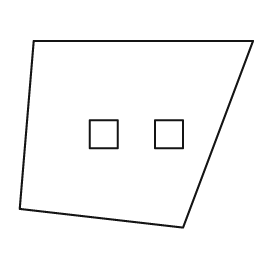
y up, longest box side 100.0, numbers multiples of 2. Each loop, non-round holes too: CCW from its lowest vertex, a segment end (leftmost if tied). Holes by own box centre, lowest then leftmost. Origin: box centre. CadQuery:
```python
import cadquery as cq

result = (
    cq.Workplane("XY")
    .moveTo(20.0, -40.0)
    .lineTo(50.0, 40.0)
    .lineTo(-44.0, 40.0)
    .lineTo(-50.0, -32.0)
    .close()
    .moveTo(-20.0, -6.0)
    .lineTo(-8.0, -6.0)
    .lineTo(-8.0, 6.0)
    .lineTo(-20.0, 6.0)
    .close()
    .moveTo(8.0, -6.0)
    .lineTo(20.0, -6.0)
    .lineTo(20.0, 6.0)
    .lineTo(8.0, 6.0)
    .close()
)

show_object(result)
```